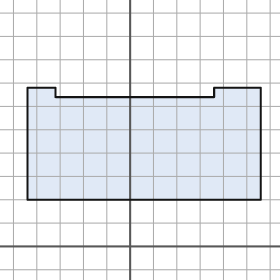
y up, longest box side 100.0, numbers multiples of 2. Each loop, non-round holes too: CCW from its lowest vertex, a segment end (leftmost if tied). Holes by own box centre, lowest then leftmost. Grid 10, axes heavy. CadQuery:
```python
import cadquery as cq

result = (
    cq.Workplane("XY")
    .moveTo(-44.0, 20.0)
    .lineTo(56.0, 20.0)
    .lineTo(56.0, 68.0)
    .lineTo(36.0, 68.0)
    .lineTo(36.0, 64.0)
    .lineTo(-32.0, 64.0)
    .lineTo(-32.0, 68.0)
    .lineTo(-44.0, 68.0)
    .close()
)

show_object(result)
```